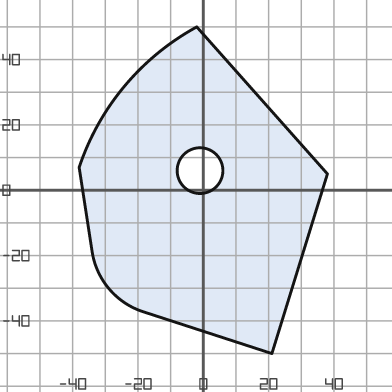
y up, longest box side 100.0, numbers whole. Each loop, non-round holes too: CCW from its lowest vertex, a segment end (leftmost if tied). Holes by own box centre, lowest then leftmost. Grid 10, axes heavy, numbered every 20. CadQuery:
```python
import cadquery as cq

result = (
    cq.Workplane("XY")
    .moveTo(21.0, -50.0)
    .lineTo(38.0, 5.0)
    .lineTo(-2.0, 50.0)
    .threePointArc((-24.0, 32.0), (-38.0, 7.0))
    .lineTo(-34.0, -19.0)
    .threePointArc((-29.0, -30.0), (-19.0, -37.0))
    .close()
    .moveTo(-1.0, 6.0)
    .circle(7.0)
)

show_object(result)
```